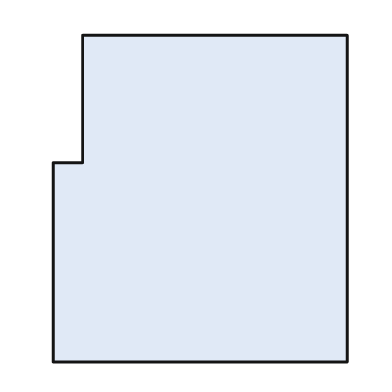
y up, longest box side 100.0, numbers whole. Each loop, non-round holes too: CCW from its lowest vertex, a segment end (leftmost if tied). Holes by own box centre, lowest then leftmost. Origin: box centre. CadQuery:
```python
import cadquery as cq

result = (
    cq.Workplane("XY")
    .moveTo(-45.0, -50.0)
    .lineTo(45.0, -50.0)
    .lineTo(45.0, 50.0)
    .lineTo(-36.0, 50.0)
    .lineTo(-36.0, 11.0)
    .lineTo(-45.0, 11.0)
    .close()
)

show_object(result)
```